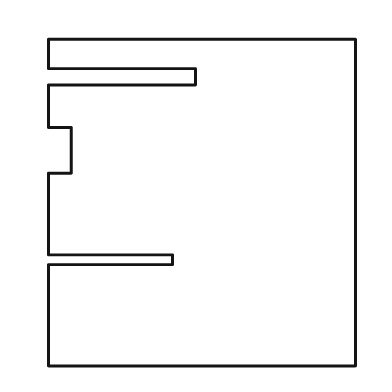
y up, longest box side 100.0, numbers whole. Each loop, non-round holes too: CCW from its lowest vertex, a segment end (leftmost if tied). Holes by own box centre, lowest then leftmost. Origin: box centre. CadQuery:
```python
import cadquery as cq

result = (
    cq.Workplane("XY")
    .moveTo(-47.0, -50.0)
    .lineTo(47.0, -50.0)
    .lineTo(47.0, 50.0)
    .lineTo(-47.0, 50.0)
    .lineTo(-47.0, 41.0)
    .lineTo(-2.0, 41.0)
    .lineTo(-2.0, 36.0)
    .lineTo(-47.0, 36.0)
    .lineTo(-47.0, 23.0)
    .lineTo(-40.0, 23.0)
    .lineTo(-40.0, 9.0)
    .lineTo(-47.0, 9.0)
    .lineTo(-47.0, -16.0)
    .lineTo(-9.0, -16.0)
    .lineTo(-9.0, -19.0)
    .lineTo(-47.0, -19.0)
    .close()
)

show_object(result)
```